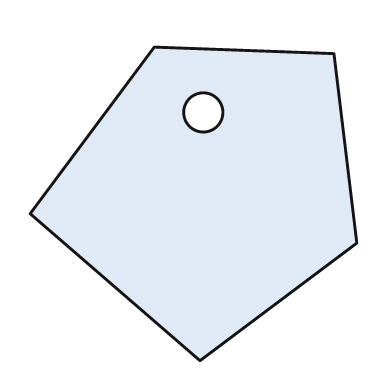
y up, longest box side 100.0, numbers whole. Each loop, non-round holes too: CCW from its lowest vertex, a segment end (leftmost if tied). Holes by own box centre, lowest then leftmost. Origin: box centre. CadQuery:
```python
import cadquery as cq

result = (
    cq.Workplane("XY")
    .moveTo(2.0, -48.0)
    .lineTo(50.0, -12.0)
    .lineTo(43.0, 46.0)
    .lineTo(-12.0, 48.0)
    .lineTo(-50.0, -3.0)
    .close()
    .moveTo(3.0, 28.0)
    .circle(6.0)
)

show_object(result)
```